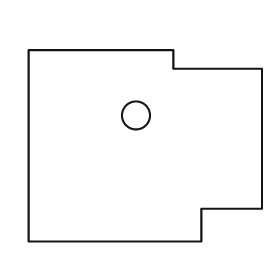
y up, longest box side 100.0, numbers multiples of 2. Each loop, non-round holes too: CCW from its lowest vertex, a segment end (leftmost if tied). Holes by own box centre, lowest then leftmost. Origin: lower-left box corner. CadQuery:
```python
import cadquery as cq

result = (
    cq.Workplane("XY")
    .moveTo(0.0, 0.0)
    .lineTo(74.0, 0.0)
    .lineTo(74.0, 14.0)
    .lineTo(100.0, 14.0)
    .lineTo(100.0, 74.0)
    .lineTo(62.0, 74.0)
    .lineTo(62.0, 82.0)
    .lineTo(0.0, 82.0)
    .close()
    .moveTo(46.0, 54.0)
    .circle(6.0)
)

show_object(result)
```